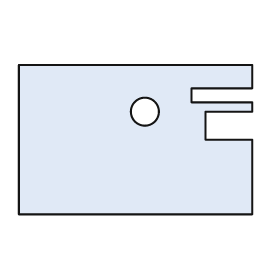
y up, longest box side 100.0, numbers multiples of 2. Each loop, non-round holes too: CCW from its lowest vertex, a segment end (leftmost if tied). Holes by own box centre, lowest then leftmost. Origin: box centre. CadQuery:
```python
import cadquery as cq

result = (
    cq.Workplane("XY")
    .moveTo(-50.0, -32.0)
    .lineTo(50.0, -32.0)
    .lineTo(50.0, 0.0)
    .lineTo(30.0, 0.0)
    .lineTo(30.0, 12.0)
    .lineTo(50.0, 12.0)
    .lineTo(50.0, 16.0)
    .lineTo(24.0, 16.0)
    .lineTo(24.0, 22.0)
    .lineTo(50.0, 22.0)
    .lineTo(50.0, 32.0)
    .lineTo(-50.0, 32.0)
    .close()
    .moveTo(4.0, 12.0)
    .circle(6.0)
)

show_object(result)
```